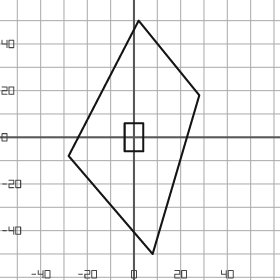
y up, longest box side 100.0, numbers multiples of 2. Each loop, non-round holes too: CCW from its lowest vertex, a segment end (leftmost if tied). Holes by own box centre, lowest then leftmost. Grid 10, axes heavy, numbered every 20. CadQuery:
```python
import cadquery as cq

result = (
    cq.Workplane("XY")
    .moveTo(8.0, -50.0)
    .lineTo(28.0, 18.0)
    .lineTo(2.0, 50.0)
    .lineTo(-28.0, -8.0)
    .close()
    .moveTo(-4.0, -6.0)
    .lineTo(4.0, -6.0)
    .lineTo(4.0, 6.0)
    .lineTo(-4.0, 6.0)
    .close()
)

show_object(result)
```